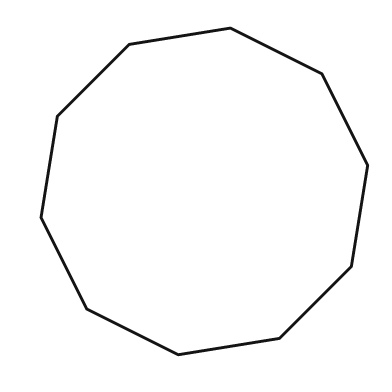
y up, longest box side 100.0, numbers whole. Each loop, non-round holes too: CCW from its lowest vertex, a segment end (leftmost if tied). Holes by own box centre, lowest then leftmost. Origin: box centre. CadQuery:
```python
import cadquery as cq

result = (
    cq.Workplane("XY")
    .moveTo(-8.0, -50.0)
    .lineTo(23.0, -45.0)
    .lineTo(45.0, -23.0)
    .lineTo(50.0, 8.0)
    .lineTo(36.0, 36.0)
    .lineTo(8.0, 50.0)
    .lineTo(-23.0, 45.0)
    .lineTo(-45.0, 23.0)
    .lineTo(-50.0, -8.0)
    .lineTo(-36.0, -36.0)
    .close()
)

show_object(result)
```